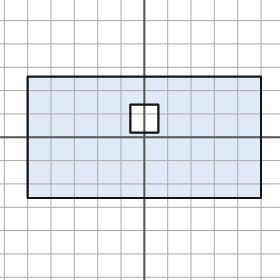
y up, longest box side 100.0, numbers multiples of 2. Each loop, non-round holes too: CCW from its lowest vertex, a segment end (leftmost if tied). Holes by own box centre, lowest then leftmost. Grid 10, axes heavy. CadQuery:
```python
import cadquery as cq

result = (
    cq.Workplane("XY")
    .moveTo(-50.0, -26.0)
    .lineTo(50.0, -26.0)
    .lineTo(50.0, 26.0)
    .lineTo(-50.0, 26.0)
    .close()
    .moveTo(-6.0, 2.0)
    .lineTo(6.0, 2.0)
    .lineTo(6.0, 14.0)
    .lineTo(-6.0, 14.0)
    .close()
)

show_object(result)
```